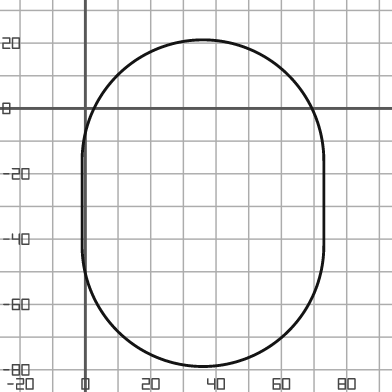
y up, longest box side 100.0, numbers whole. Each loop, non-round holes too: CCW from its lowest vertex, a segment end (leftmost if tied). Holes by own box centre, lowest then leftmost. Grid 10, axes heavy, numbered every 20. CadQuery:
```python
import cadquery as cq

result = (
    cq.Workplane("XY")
    .moveTo(-1.0, -42.0)
    .threePointArc((36.0, -79.0), (73.0, -42.0))
    .lineTo(73.0, -16.0)
    .threePointArc((36.0, 21.0), (-1.0, -16.0))
    .close()
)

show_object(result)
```